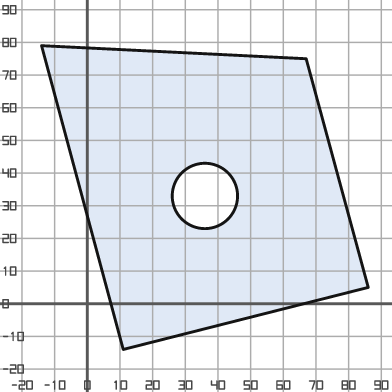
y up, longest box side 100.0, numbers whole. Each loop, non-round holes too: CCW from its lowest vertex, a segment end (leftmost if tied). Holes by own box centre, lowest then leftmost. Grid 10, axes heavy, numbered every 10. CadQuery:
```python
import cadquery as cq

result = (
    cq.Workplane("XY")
    .moveTo(11.0, -14.0)
    .lineTo(86.0, 5.0)
    .lineTo(67.0, 75.0)
    .lineTo(-14.0, 79.0)
    .close()
    .moveTo(36.0, 33.0)
    .circle(10.0)
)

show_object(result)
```